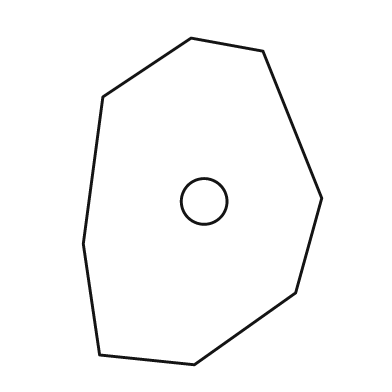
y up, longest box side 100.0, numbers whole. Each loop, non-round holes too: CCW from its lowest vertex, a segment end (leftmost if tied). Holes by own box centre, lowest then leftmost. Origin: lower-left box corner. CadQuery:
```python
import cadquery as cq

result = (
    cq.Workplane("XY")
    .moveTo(34.0, 0.0)
    .lineTo(65.0, 22.0)
    .lineTo(73.0, 51.0)
    .lineTo(55.0, 96.0)
    .lineTo(33.0, 100.0)
    .lineTo(6.0, 82.0)
    .lineTo(0.0, 37.0)
    .lineTo(5.0, 3.0)
    .close()
    .moveTo(37.0, 50.0)
    .circle(7.0)
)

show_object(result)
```